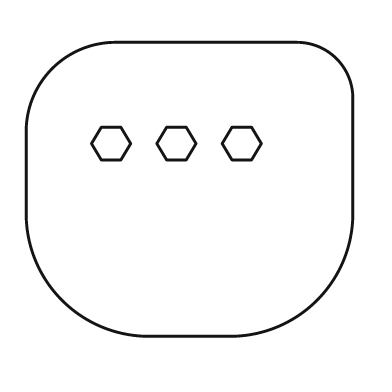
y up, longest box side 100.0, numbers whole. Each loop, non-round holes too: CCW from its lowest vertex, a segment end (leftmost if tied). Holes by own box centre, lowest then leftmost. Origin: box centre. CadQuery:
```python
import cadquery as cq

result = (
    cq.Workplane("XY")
    .moveTo(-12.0, -45.0)
    .lineTo(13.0, -45.0)
    .threePointArc((39.0, -34.0), (50.0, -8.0))
    .lineTo(50.0, 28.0)
    .threePointArc((45.0, 40.0), (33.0, 45.0))
    .lineTo(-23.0, 45.0)
    .threePointArc((-42.0, 37.0), (-50.0, 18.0))
    .lineTo(-50.0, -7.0)
    .threePointArc((-39.0, -34.0), (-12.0, -45.0))
    .close()
    .moveTo(-27.0, 9.0)
    .lineTo(-21.0, 9.0)
    .lineTo(-18.0, 14.0)
    .lineTo(-21.0, 19.0)
    .lineTo(-27.0, 19.0)
    .lineTo(-30.0, 14.0)
    .close()
    .moveTo(-7.0, 9.0)
    .lineTo(-1.0, 9.0)
    .lineTo(2.0, 14.0)
    .lineTo(-1.0, 19.0)
    .lineTo(-7.0, 19.0)
    .lineTo(-10.0, 14.0)
    .close()
    .moveTo(13.0, 9.0)
    .lineTo(19.0, 9.0)
    .lineTo(22.0, 14.0)
    .lineTo(19.0, 19.0)
    .lineTo(13.0, 19.0)
    .lineTo(10.0, 14.0)
    .close()
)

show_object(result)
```